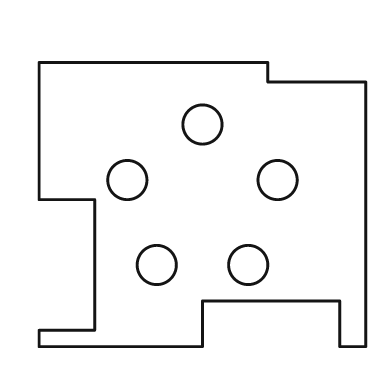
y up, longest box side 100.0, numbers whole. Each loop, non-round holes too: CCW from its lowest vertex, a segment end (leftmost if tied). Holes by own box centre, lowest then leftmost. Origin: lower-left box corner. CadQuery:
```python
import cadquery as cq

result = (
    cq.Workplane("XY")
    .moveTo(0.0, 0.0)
    .lineTo(50.0, 0.0)
    .lineTo(50.0, 14.0)
    .lineTo(92.0, 14.0)
    .lineTo(92.0, 0.0)
    .lineTo(100.0, 0.0)
    .lineTo(100.0, 81.0)
    .lineTo(70.0, 81.0)
    .lineTo(70.0, 87.0)
    .lineTo(0.0, 87.0)
    .lineTo(0.0, 45.0)
    .lineTo(17.0, 45.0)
    .lineTo(17.0, 5.0)
    .lineTo(0.0, 5.0)
    .close()
    .moveTo(36.0, 25.0)
    .circle(6.0)
    .moveTo(64.0, 25.0)
    .circle(6.0)
    .moveTo(27.0, 51.0)
    .circle(6.0)
    .moveTo(73.0, 51.0)
    .circle(6.0)
    .moveTo(50.0, 68.0)
    .circle(6.0)
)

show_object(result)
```